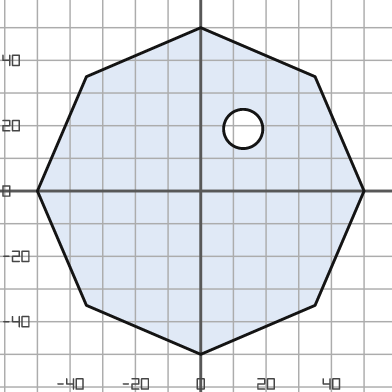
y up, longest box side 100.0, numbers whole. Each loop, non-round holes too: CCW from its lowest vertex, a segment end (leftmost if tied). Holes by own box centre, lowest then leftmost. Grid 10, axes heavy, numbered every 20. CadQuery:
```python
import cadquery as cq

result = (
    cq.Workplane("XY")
    .moveTo(0.0, -50.0)
    .lineTo(35.0, -35.0)
    .lineTo(50.0, 0.0)
    .lineTo(35.0, 35.0)
    .lineTo(0.0, 50.0)
    .lineTo(-35.0, 35.0)
    .lineTo(-50.0, 0.0)
    .lineTo(-35.0, -35.0)
    .close()
    .moveTo(13.0, 19.0)
    .circle(6.0)
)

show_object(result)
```